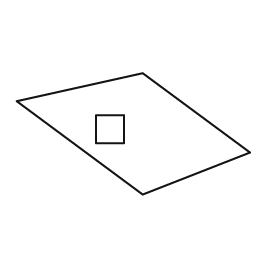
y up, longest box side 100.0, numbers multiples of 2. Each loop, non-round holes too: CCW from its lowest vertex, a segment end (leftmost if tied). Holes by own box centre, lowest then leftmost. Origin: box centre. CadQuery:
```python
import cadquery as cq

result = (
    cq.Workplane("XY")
    .moveTo(4.0, -26.0)
    .lineTo(50.0, -8.0)
    .lineTo(4.0, 26.0)
    .lineTo(-50.0, 14.0)
    .close()
    .moveTo(-16.0, -4.0)
    .lineTo(-4.0, -4.0)
    .lineTo(-4.0, 8.0)
    .lineTo(-16.0, 8.0)
    .close()
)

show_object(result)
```